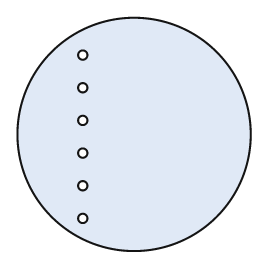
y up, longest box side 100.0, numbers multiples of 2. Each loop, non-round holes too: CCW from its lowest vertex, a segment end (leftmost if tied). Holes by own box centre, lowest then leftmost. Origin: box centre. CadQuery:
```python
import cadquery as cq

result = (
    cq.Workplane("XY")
    .moveTo(0.0, 0.0)
    .circle(50.0)
    .moveTo(-22.0, -36.0)
    .circle(2.0)
    .moveTo(-22.0, -22.0)
    .circle(2.0)
    .moveTo(-22.0, -8.0)
    .circle(2.0)
    .moveTo(-22.0, 6.0)
    .circle(2.0)
    .moveTo(-22.0, 20.0)
    .circle(2.0)
    .moveTo(-22.0, 34.0)
    .circle(2.0)
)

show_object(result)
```